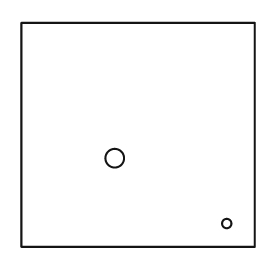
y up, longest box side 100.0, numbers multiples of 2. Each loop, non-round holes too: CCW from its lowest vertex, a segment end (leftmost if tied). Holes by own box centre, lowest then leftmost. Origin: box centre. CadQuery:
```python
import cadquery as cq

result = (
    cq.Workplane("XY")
    .moveTo(-50.0, -48.0)
    .lineTo(50.0, -48.0)
    .lineTo(50.0, 48.0)
    .lineTo(-50.0, 48.0)
    .close()
    .moveTo(38.0, -38.0)
    .circle(2.0)
    .moveTo(-10.0, -10.0)
    .circle(4.0)
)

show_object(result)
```